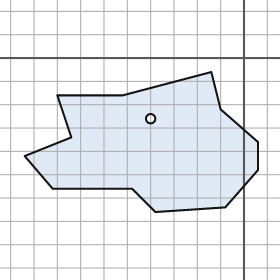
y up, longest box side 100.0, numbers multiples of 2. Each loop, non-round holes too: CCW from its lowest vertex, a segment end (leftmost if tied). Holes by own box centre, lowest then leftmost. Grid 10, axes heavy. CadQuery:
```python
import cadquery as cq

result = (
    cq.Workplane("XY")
    .moveTo(-38.0, -66.0)
    .lineTo(-8.0, -64.0)
    .lineTo(6.0, -48.0)
    .lineTo(6.0, -36.0)
    .lineTo(-10.0, -22.0)
    .lineTo(-14.0, -6.0)
    .lineTo(-52.0, -16.0)
    .lineTo(-80.0, -16.0)
    .lineTo(-74.0, -34.0)
    .lineTo(-94.0, -42.0)
    .lineTo(-82.0, -56.0)
    .lineTo(-48.0, -56.0)
    .close()
    .moveTo(-40.0, -26.0)
    .circle(2.0)
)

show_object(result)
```